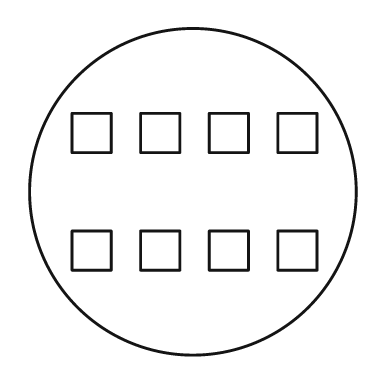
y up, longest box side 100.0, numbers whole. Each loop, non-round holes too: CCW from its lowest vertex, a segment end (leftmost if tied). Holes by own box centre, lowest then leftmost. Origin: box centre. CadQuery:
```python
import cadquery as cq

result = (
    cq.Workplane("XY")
    .moveTo(0.0, 0.0)
    .circle(50.0)
    .moveTo(-37.0, -24.0)
    .lineTo(-25.0, -24.0)
    .lineTo(-25.0, -12.0)
    .lineTo(-37.0, -12.0)
    .close()
    .moveTo(-16.0, -24.0)
    .lineTo(-4.0, -24.0)
    .lineTo(-4.0, -12.0)
    .lineTo(-16.0, -12.0)
    .close()
    .moveTo(5.0, -24.0)
    .lineTo(17.0, -24.0)
    .lineTo(17.0, -12.0)
    .lineTo(5.0, -12.0)
    .close()
    .moveTo(26.0, -24.0)
    .lineTo(38.0, -24.0)
    .lineTo(38.0, -12.0)
    .lineTo(26.0, -12.0)
    .close()
    .moveTo(-37.0, 12.0)
    .lineTo(-25.0, 12.0)
    .lineTo(-25.0, 24.0)
    .lineTo(-37.0, 24.0)
    .close()
    .moveTo(-16.0, 12.0)
    .lineTo(-4.0, 12.0)
    .lineTo(-4.0, 24.0)
    .lineTo(-16.0, 24.0)
    .close()
    .moveTo(5.0, 12.0)
    .lineTo(17.0, 12.0)
    .lineTo(17.0, 24.0)
    .lineTo(5.0, 24.0)
    .close()
    .moveTo(26.0, 12.0)
    .lineTo(38.0, 12.0)
    .lineTo(38.0, 24.0)
    .lineTo(26.0, 24.0)
    .close()
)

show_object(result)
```